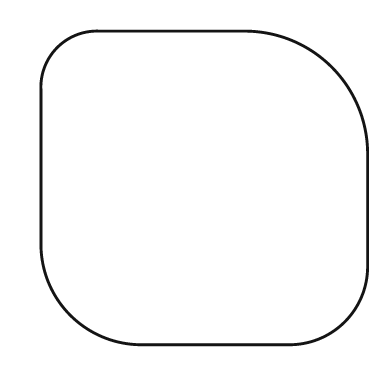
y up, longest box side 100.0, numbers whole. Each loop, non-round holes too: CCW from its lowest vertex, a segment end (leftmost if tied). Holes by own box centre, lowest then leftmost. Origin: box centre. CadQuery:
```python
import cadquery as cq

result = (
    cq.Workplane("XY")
    .moveTo(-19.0, -48.0)
    .lineTo(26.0, -48.0)
    .threePointArc((43.0, -41.0), (50.0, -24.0))
    .lineTo(50.0, 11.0)
    .threePointArc((39.0, 37.0), (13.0, 48.0))
    .lineTo(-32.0, 48.0)
    .threePointArc((-45.0, 43.0), (-50.0, 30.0))
    .lineTo(-50.0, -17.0)
    .threePointArc((-41.0, -39.0), (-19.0, -48.0))
    .close()
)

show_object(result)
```